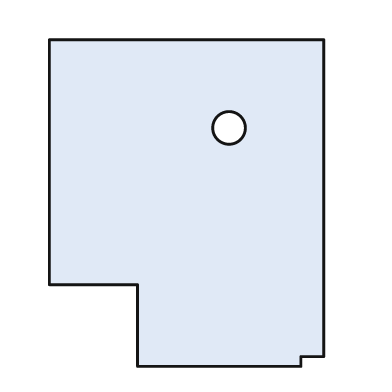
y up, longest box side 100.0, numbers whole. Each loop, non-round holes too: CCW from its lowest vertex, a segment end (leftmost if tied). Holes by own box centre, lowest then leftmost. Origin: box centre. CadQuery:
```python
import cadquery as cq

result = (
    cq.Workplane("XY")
    .moveTo(-15.0, -50.0)
    .lineTo(35.0, -50.0)
    .lineTo(35.0, -47.0)
    .lineTo(42.0, -47.0)
    .lineTo(42.0, 50.0)
    .lineTo(-42.0, 50.0)
    .lineTo(-42.0, -25.0)
    .lineTo(-15.0, -25.0)
    .close()
    .moveTo(13.0, 23.0)
    .circle(5.0)
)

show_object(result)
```